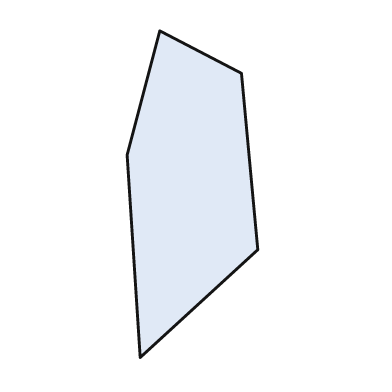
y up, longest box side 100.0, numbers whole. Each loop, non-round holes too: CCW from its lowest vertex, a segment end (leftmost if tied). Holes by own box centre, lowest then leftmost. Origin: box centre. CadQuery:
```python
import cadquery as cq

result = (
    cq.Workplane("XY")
    .moveTo(-16.0, -50.0)
    .lineTo(20.0, -17.0)
    .lineTo(15.0, 37.0)
    .lineTo(-10.0, 50.0)
    .lineTo(-20.0, 12.0)
    .close()
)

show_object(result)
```